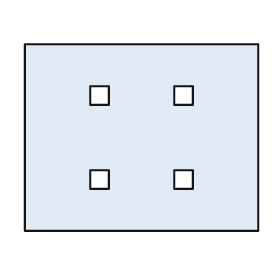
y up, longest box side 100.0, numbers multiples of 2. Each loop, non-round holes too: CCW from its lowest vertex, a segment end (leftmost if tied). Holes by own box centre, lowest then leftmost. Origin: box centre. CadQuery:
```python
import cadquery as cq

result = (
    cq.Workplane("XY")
    .moveTo(-50.0, -40.0)
    .lineTo(50.0, -40.0)
    .lineTo(50.0, 40.0)
    .lineTo(-50.0, 40.0)
    .close()
    .moveTo(-22.0, -22.0)
    .lineTo(-14.0, -22.0)
    .lineTo(-14.0, -14.0)
    .lineTo(-22.0, -14.0)
    .close()
    .moveTo(14.0, -22.0)
    .lineTo(22.0, -22.0)
    .lineTo(22.0, -14.0)
    .lineTo(14.0, -14.0)
    .close()
    .moveTo(-22.0, 14.0)
    .lineTo(-14.0, 14.0)
    .lineTo(-14.0, 22.0)
    .lineTo(-22.0, 22.0)
    .close()
    .moveTo(14.0, 14.0)
    .lineTo(22.0, 14.0)
    .lineTo(22.0, 22.0)
    .lineTo(14.0, 22.0)
    .close()
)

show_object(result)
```